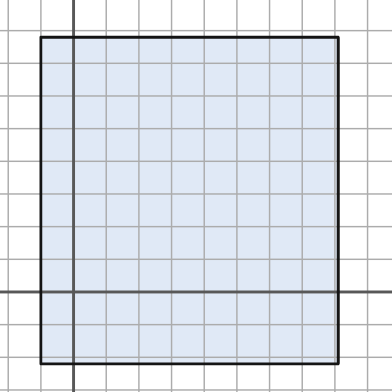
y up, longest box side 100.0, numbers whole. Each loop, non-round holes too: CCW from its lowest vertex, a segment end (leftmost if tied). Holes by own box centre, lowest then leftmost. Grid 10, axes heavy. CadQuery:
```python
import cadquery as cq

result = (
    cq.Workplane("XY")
    .moveTo(-10.0, -22.0)
    .lineTo(81.0, -22.0)
    .lineTo(81.0, 78.0)
    .lineTo(-10.0, 78.0)
    .close()
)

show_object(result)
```